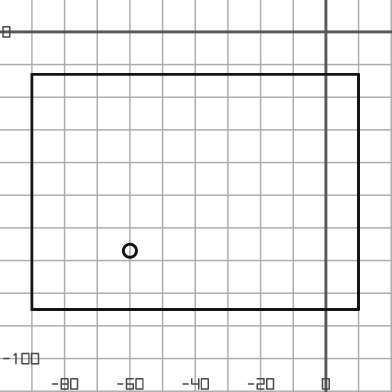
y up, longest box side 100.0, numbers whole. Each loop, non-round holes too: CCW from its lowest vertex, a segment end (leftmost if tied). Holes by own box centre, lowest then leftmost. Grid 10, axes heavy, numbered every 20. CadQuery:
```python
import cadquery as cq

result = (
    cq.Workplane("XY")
    .moveTo(-90.0, -85.0)
    .lineTo(10.0, -85.0)
    .lineTo(10.0, -13.0)
    .lineTo(-90.0, -13.0)
    .close()
    .moveTo(-60.0, -67.0)
    .circle(2.0)
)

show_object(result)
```